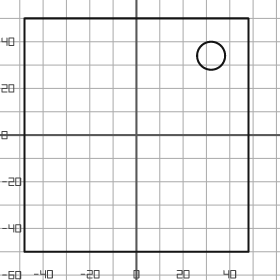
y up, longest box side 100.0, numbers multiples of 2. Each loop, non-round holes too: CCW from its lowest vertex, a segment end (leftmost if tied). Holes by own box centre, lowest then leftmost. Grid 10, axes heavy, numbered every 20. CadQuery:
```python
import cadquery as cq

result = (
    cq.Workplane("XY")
    .moveTo(-48.0, -50.0)
    .lineTo(48.0, -50.0)
    .lineTo(48.0, 50.0)
    .lineTo(-48.0, 50.0)
    .close()
    .moveTo(32.0, 34.0)
    .circle(6.0)
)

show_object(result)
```